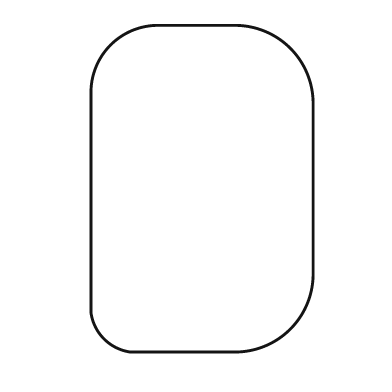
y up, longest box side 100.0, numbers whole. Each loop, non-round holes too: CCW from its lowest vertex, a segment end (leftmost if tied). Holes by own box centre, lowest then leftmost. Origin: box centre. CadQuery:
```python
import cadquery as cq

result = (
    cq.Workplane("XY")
    .moveTo(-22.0, -50.0)
    .lineTo(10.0, -50.0)
    .threePointArc((27.0, -43.0), (34.0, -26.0))
    .lineTo(34.0, 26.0)
    .threePointArc((27.0, 43.0), (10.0, 50.0))
    .lineTo(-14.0, 50.0)
    .threePointArc((-28.0, 44.0), (-34.0, 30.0))
    .lineTo(-34.0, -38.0)
    .threePointArc((-30.0, -46.0), (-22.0, -50.0))
    .close()
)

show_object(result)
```